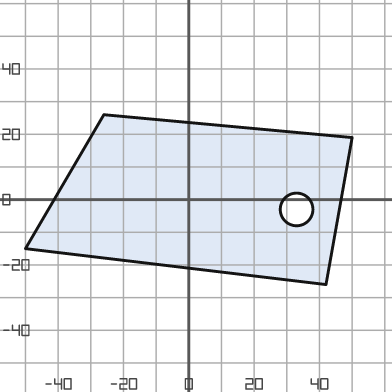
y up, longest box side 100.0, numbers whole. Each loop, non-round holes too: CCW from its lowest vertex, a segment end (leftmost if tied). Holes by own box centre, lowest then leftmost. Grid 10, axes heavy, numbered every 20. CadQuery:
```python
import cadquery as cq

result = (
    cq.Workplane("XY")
    .moveTo(42.0, -26.0)
    .lineTo(50.0, 19.0)
    .lineTo(-26.0, 26.0)
    .lineTo(-50.0, -15.0)
    .close()
    .moveTo(33.0, -3.0)
    .circle(5.0)
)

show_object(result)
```